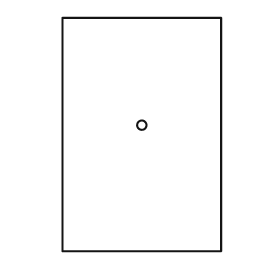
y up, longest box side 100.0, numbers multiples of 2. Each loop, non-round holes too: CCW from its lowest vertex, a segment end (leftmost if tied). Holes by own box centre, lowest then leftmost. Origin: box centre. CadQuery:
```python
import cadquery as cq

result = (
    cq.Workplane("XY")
    .moveTo(-34.0, -50.0)
    .lineTo(34.0, -50.0)
    .lineTo(34.0, 50.0)
    .lineTo(-34.0, 50.0)
    .close()
    .moveTo(0.0, 4.0)
    .circle(2.0)
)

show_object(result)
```